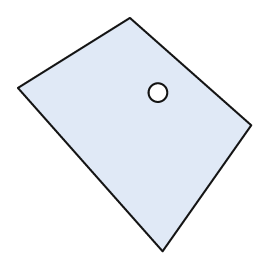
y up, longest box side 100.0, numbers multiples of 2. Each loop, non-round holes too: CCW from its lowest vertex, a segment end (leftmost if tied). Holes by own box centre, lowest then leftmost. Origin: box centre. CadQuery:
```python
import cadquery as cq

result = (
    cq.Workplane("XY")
    .moveTo(12.0, -50.0)
    .lineTo(50.0, 4.0)
    .lineTo(-2.0, 50.0)
    .lineTo(-50.0, 20.0)
    .close()
    .moveTo(10.0, 18.0)
    .circle(4.0)
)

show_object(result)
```